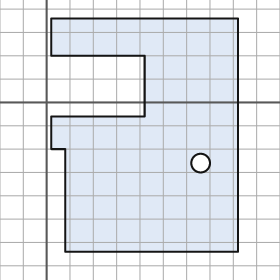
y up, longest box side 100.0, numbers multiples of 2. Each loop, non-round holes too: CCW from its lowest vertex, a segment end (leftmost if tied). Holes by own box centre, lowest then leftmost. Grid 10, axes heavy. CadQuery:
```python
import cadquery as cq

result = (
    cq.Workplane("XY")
    .moveTo(8.0, -64.0)
    .lineTo(82.0, -64.0)
    .lineTo(82.0, 36.0)
    .lineTo(2.0, 36.0)
    .lineTo(2.0, 20.0)
    .lineTo(42.0, 20.0)
    .lineTo(42.0, -6.0)
    .lineTo(2.0, -6.0)
    .lineTo(2.0, -20.0)
    .lineTo(8.0, -20.0)
    .close()
    .moveTo(66.0, -26.0)
    .circle(4.0)
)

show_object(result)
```